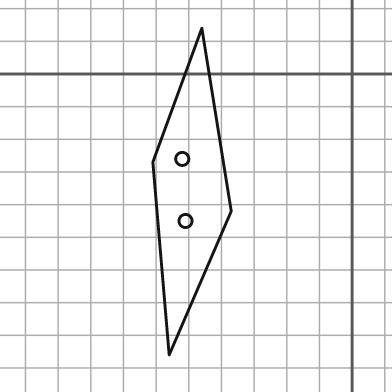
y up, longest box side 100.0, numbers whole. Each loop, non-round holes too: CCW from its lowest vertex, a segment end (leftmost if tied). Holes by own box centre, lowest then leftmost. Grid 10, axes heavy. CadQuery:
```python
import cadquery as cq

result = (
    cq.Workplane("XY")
    .moveTo(-56.0, -86.0)
    .lineTo(-37.0, -42.0)
    .lineTo(-46.0, 14.0)
    .lineTo(-61.0, -27.0)
    .close()
    .moveTo(-51.0, -45.0)
    .circle(2.0)
    .moveTo(-52.0, -26.0)
    .circle(2.0)
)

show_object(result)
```